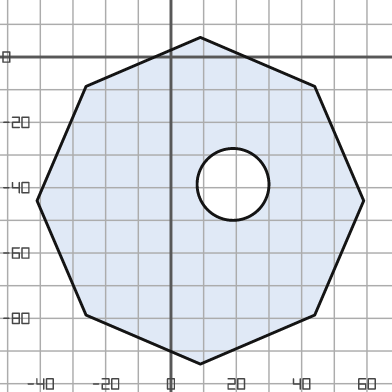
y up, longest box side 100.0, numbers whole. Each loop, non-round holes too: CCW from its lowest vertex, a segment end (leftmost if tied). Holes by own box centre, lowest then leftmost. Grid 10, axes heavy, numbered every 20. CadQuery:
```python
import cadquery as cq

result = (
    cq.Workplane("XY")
    .moveTo(9.0, -94.0)
    .lineTo(44.0, -79.0)
    .lineTo(59.0, -44.0)
    .lineTo(44.0, -9.0)
    .lineTo(9.0, 6.0)
    .lineTo(-26.0, -9.0)
    .lineTo(-41.0, -44.0)
    .lineTo(-26.0, -79.0)
    .close()
    .moveTo(19.0, -39.0)
    .circle(11.0)
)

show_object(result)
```